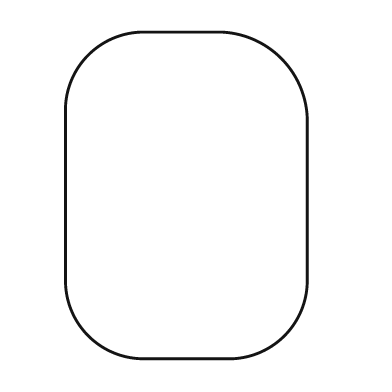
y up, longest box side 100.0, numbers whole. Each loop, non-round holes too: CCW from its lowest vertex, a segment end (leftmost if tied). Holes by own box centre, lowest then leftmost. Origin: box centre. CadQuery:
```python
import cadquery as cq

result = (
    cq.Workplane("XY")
    .moveTo(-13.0, -50.0)
    .lineTo(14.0, -50.0)
    .threePointArc((30.0, -43.0), (37.0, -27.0))
    .lineTo(37.0, 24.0)
    .threePointArc((29.0, 42.0), (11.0, 50.0))
    .lineTo(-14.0, 50.0)
    .threePointArc((-30.0, 43.0), (-37.0, 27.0))
    .lineTo(-37.0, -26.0)
    .threePointArc((-30.0, -43.0), (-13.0, -50.0))
    .close()
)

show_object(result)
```